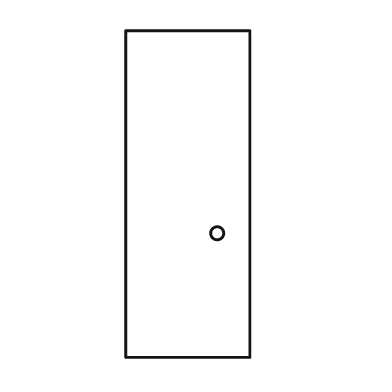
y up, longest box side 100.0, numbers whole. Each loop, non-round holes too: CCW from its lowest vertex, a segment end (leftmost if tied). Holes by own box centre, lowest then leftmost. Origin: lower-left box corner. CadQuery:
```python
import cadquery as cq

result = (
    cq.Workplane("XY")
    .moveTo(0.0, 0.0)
    .lineTo(38.0, 0.0)
    .lineTo(38.0, 100.0)
    .lineTo(0.0, 100.0)
    .close()
    .moveTo(28.0, 38.0)
    .circle(2.0)
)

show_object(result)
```